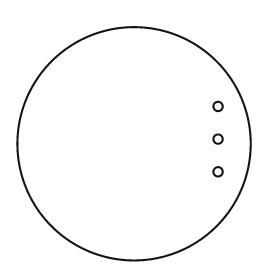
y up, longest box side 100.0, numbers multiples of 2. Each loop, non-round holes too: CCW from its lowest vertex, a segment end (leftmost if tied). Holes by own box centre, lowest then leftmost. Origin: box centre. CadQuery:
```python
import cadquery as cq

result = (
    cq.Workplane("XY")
    .moveTo(0.0, 0.0)
    .circle(50.0)
    .moveTo(36.0, -12.0)
    .circle(2.0)
    .moveTo(36.0, 2.0)
    .circle(2.0)
    .moveTo(36.0, 16.0)
    .circle(2.0)
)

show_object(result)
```